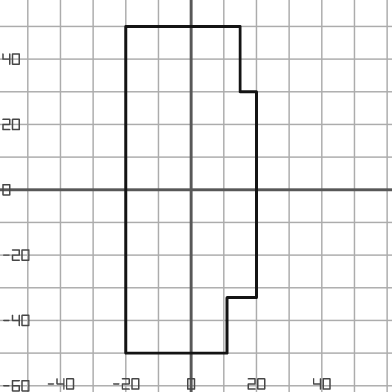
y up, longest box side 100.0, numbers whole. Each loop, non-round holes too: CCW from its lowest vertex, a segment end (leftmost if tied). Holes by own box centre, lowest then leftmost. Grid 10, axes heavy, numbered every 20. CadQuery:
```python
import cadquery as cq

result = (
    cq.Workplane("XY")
    .moveTo(-20.0, -50.0)
    .lineTo(11.0, -50.0)
    .lineTo(11.0, -33.0)
    .lineTo(20.0, -33.0)
    .lineTo(20.0, 30.0)
    .lineTo(15.0, 30.0)
    .lineTo(15.0, 50.0)
    .lineTo(-20.0, 50.0)
    .close()
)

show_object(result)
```